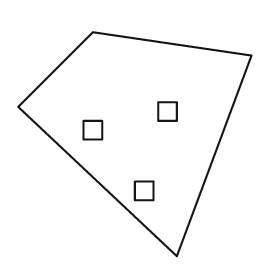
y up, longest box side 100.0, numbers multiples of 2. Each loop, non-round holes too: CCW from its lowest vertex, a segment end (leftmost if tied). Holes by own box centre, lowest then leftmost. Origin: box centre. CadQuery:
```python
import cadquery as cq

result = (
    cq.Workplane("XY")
    .moveTo(18.0, -48.0)
    .lineTo(50.0, 38.0)
    .lineTo(-18.0, 48.0)
    .lineTo(-50.0, 16.0)
    .close()
    .moveTo(0.0, -24.0)
    .lineTo(8.0, -24.0)
    .lineTo(8.0, -16.0)
    .lineTo(0.0, -16.0)
    .close()
    .moveTo(-22.0, 2.0)
    .lineTo(-14.0, 2.0)
    .lineTo(-14.0, 10.0)
    .lineTo(-22.0, 10.0)
    .close()
    .moveTo(10.0, 10.0)
    .lineTo(18.0, 10.0)
    .lineTo(18.0, 18.0)
    .lineTo(10.0, 18.0)
    .close()
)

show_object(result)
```